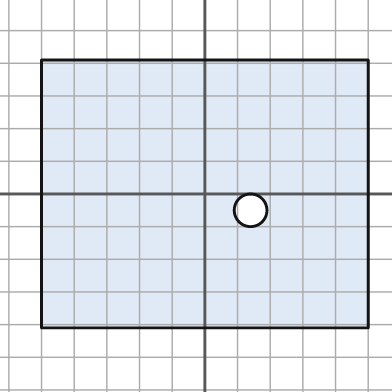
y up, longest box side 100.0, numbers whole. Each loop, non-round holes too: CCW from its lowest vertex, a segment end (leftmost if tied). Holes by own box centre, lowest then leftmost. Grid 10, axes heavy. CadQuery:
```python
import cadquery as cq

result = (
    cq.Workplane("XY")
    .moveTo(-50.0, -41.0)
    .lineTo(50.0, -41.0)
    .lineTo(50.0, 41.0)
    .lineTo(-50.0, 41.0)
    .close()
    .moveTo(14.0, -5.0)
    .circle(5.0)
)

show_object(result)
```